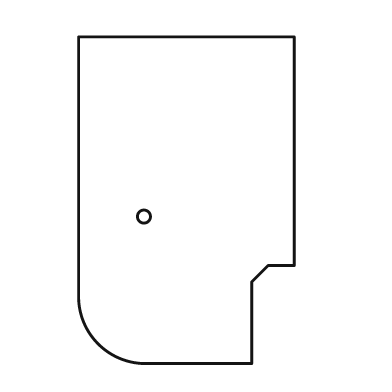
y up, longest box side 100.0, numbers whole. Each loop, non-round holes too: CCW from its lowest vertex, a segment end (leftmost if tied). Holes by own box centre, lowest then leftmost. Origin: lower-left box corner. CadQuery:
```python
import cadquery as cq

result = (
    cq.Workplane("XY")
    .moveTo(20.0, 0.0)
    .lineTo(53.0, 0.0)
    .lineTo(53.0, 25.0)
    .lineTo(58.0, 30.0)
    .lineTo(66.0, 30.0)
    .lineTo(66.0, 100.0)
    .lineTo(0.0, 100.0)
    .lineTo(0.0, 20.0)
    .threePointArc((6.0, 6.0), (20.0, 0.0))
    .close()
    .moveTo(20.0, 45.0)
    .circle(2.0)
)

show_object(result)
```